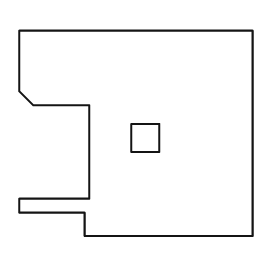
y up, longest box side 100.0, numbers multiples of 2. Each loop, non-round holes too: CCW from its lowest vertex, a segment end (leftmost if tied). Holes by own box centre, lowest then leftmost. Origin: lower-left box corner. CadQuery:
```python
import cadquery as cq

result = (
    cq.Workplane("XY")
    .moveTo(28.0, 0.0)
    .lineTo(100.0, 0.0)
    .lineTo(100.0, 88.0)
    .lineTo(0.0, 88.0)
    .lineTo(0.0, 62.0)
    .lineTo(6.0, 56.0)
    .lineTo(30.0, 56.0)
    .lineTo(30.0, 16.0)
    .lineTo(0.0, 16.0)
    .lineTo(0.0, 10.0)
    .lineTo(28.0, 10.0)
    .close()
    .moveTo(48.0, 36.0)
    .lineTo(60.0, 36.0)
    .lineTo(60.0, 48.0)
    .lineTo(48.0, 48.0)
    .close()
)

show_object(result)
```